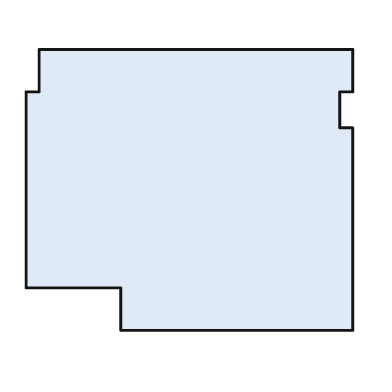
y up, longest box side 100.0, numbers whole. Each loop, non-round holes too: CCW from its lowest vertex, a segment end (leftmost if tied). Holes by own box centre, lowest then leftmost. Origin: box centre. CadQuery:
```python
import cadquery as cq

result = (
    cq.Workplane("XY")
    .moveTo(-21.0, -43.0)
    .lineTo(50.0, -43.0)
    .lineTo(50.0, 19.0)
    .lineTo(46.0, 19.0)
    .lineTo(46.0, 30.0)
    .lineTo(50.0, 30.0)
    .lineTo(50.0, 43.0)
    .lineTo(-46.0, 43.0)
    .lineTo(-46.0, 30.0)
    .lineTo(-50.0, 30.0)
    .lineTo(-50.0, -30.0)
    .lineTo(-21.0, -30.0)
    .close()
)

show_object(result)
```